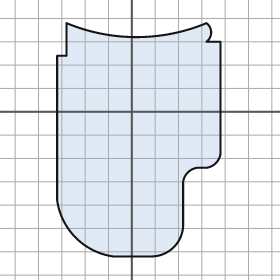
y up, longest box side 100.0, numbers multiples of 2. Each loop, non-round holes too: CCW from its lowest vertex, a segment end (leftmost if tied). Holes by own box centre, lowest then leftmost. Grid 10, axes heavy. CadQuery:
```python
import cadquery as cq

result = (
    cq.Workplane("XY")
    .moveTo(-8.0, -62.0)
    .lineTo(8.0, -62.0)
    .threePointArc((18.0, -58.0), (22.0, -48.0))
    .lineTo(22.0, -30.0)
    .threePointArc((24.0, -26.0), (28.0, -24.0))
    .lineTo(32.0, -24.0)
    .threePointArc((36.0, -22.0), (38.0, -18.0))
    .lineTo(38.0, 30.0)
    .lineTo(32.0, 30.0)
    .threePointArc((34.0, 34.0), (32.0, 38.0))
    .threePointArc((2.0, 32.0), (-28.0, 38.0))
    .lineTo(-28.0, 24.0)
    .lineTo(-32.0, 24.0)
    .lineTo(-32.0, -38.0)
    .threePointArc((-24.0, -54.0), (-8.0, -62.0))
    .close()
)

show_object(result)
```